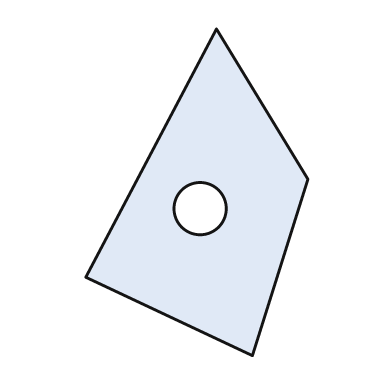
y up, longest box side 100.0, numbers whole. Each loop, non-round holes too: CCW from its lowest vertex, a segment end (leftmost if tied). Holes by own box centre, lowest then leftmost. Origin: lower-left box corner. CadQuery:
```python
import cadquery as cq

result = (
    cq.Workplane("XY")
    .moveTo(51.0, 0.0)
    .lineTo(68.0, 54.0)
    .lineTo(40.0, 100.0)
    .lineTo(0.0, 24.0)
    .close()
    .moveTo(35.0, 45.0)
    .circle(8.0)
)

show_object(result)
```